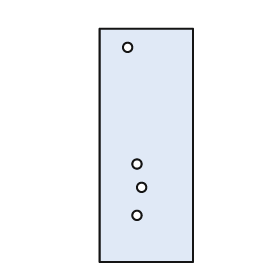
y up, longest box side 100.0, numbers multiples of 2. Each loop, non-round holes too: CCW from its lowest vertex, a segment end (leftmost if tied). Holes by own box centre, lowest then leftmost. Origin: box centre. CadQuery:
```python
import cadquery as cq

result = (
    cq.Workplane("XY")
    .moveTo(-20.0, -50.0)
    .lineTo(20.0, -50.0)
    .lineTo(20.0, 50.0)
    .lineTo(-20.0, 50.0)
    .close()
    .moveTo(-4.0, -30.0)
    .circle(2.0)
    .moveTo(-2.0, -18.0)
    .circle(2.0)
    .moveTo(-4.0, -8.0)
    .circle(2.0)
    .moveTo(-8.0, 42.0)
    .circle(2.0)
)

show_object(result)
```